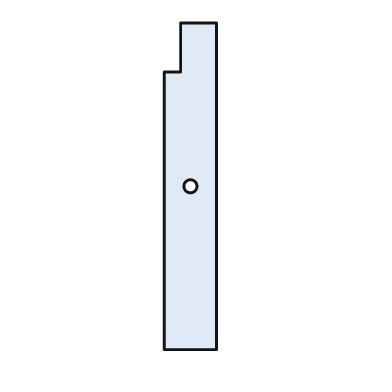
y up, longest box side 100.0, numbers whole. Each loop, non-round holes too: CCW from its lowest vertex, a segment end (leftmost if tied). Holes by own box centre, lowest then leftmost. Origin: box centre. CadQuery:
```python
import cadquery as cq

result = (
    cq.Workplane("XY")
    .moveTo(-8.0, -50.0)
    .lineTo(8.0, -50.0)
    .lineTo(8.0, 50.0)
    .lineTo(-3.0, 50.0)
    .lineTo(-3.0, 35.0)
    .lineTo(-8.0, 35.0)
    .close()
    .moveTo(0.0, 0.0)
    .circle(2.0)
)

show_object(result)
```